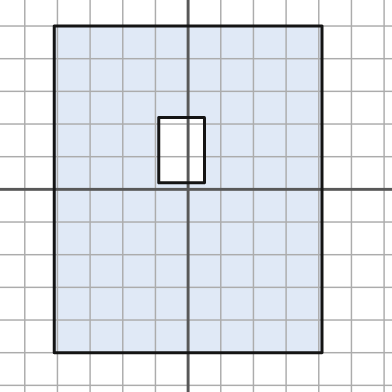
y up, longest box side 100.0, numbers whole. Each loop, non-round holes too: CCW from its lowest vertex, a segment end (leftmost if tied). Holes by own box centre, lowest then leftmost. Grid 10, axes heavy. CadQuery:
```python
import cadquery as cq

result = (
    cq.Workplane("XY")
    .moveTo(-41.0, -50.0)
    .lineTo(41.0, -50.0)
    .lineTo(41.0, 50.0)
    .lineTo(-41.0, 50.0)
    .close()
    .moveTo(-9.0, 2.0)
    .lineTo(5.0, 2.0)
    .lineTo(5.0, 22.0)
    .lineTo(-9.0, 22.0)
    .close()
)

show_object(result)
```